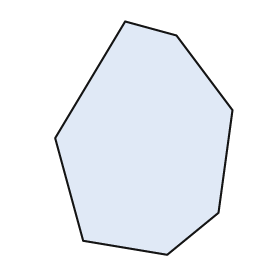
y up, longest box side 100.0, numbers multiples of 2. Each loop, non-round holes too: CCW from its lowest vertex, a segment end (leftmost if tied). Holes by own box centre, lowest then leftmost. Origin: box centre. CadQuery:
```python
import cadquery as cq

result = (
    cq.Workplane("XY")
    .moveTo(10.0, -50.0)
    .lineTo(32.0, -32.0)
    .lineTo(38.0, 12.0)
    .lineTo(14.0, 44.0)
    .lineTo(-8.0, 50.0)
    .lineTo(-38.0, 0.0)
    .lineTo(-26.0, -44.0)
    .close()
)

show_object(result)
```